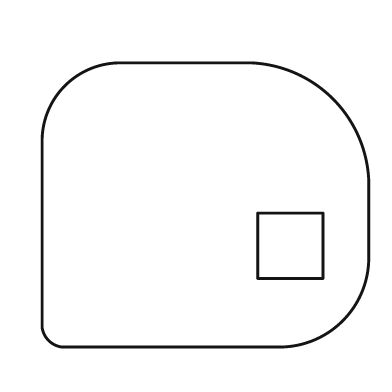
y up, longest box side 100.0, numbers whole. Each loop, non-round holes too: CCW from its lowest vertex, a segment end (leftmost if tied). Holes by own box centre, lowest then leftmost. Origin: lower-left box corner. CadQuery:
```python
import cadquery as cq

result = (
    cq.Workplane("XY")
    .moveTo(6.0, 0.0)
    .lineTo(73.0, 0.0)
    .threePointArc((92.0, 8.0), (100.0, 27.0))
    .lineTo(100.0, 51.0)
    .threePointArc((89.0, 76.0), (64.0, 87.0))
    .lineTo(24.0, 87.0)
    .threePointArc((7.0, 80.0), (0.0, 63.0))
    .lineTo(0.0, 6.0)
    .threePointArc((2.0, 2.0), (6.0, 0.0))
    .close()
    .moveTo(66.0, 21.0)
    .lineTo(86.0, 21.0)
    .lineTo(86.0, 41.0)
    .lineTo(66.0, 41.0)
    .close()
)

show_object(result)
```